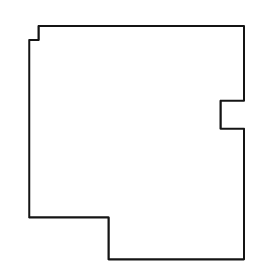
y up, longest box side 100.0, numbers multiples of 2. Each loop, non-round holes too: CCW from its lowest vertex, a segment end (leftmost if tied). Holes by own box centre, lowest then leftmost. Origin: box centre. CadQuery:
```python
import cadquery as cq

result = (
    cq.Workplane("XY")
    .moveTo(-12.0, -50.0)
    .lineTo(46.0, -50.0)
    .lineTo(46.0, 6.0)
    .lineTo(36.0, 6.0)
    .lineTo(36.0, 18.0)
    .lineTo(46.0, 18.0)
    .lineTo(46.0, 50.0)
    .lineTo(-42.0, 50.0)
    .lineTo(-42.0, 44.0)
    .lineTo(-46.0, 44.0)
    .lineTo(-46.0, -32.0)
    .lineTo(-12.0, -32.0)
    .close()
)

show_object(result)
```